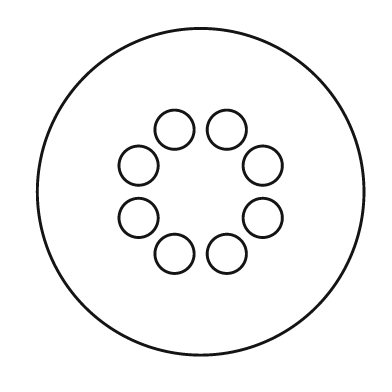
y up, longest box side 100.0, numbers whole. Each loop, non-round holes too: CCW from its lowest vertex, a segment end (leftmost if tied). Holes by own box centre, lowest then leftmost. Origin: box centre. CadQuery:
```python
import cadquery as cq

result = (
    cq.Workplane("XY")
    .moveTo(0.0, 0.0)
    .circle(50.0)
    .moveTo(-8.0, -19.0)
    .circle(6.0)
    .moveTo(8.0, -19.0)
    .circle(6.0)
    .moveTo(-19.0, -8.0)
    .circle(6.0)
    .moveTo(19.0, -8.0)
    .circle(6.0)
    .moveTo(-19.0, 8.0)
    .circle(6.0)
    .moveTo(19.0, 8.0)
    .circle(6.0)
    .moveTo(-8.0, 19.0)
    .circle(6.0)
    .moveTo(8.0, 19.0)
    .circle(6.0)
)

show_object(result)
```